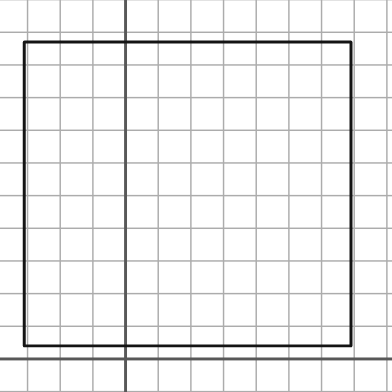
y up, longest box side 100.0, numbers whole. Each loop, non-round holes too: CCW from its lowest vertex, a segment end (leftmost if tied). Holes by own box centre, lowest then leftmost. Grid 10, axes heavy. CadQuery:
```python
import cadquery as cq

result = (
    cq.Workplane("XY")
    .moveTo(-31.0, 4.0)
    .lineTo(69.0, 4.0)
    .lineTo(69.0, 97.0)
    .lineTo(-31.0, 97.0)
    .close()
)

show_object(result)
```